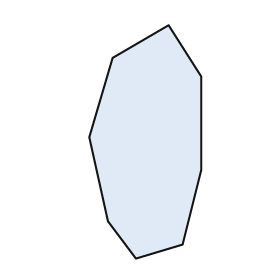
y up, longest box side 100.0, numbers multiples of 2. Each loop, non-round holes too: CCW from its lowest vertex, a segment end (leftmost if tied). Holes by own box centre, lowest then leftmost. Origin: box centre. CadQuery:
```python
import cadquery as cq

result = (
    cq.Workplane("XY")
    .moveTo(-4.0, -50.0)
    .lineTo(16.0, -44.0)
    .lineTo(24.0, -12.0)
    .lineTo(24.0, 28.0)
    .lineTo(10.0, 50.0)
    .lineTo(-14.0, 36.0)
    .lineTo(-24.0, 2.0)
    .lineTo(-16.0, -34.0)
    .close()
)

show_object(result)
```